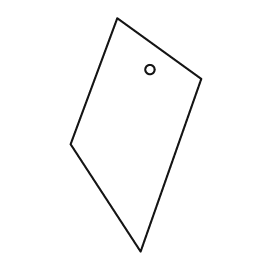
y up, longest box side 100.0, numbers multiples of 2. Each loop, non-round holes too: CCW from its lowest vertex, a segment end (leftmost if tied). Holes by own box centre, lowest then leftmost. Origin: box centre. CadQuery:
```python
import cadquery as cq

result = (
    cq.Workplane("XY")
    .moveTo(2.0, -50.0)
    .lineTo(28.0, 24.0)
    .lineTo(-8.0, 50.0)
    .lineTo(-28.0, -4.0)
    .close()
    .moveTo(6.0, 28.0)
    .circle(2.0)
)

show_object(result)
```